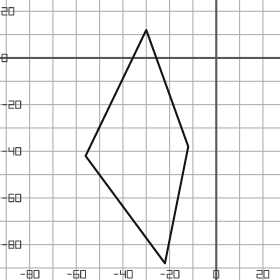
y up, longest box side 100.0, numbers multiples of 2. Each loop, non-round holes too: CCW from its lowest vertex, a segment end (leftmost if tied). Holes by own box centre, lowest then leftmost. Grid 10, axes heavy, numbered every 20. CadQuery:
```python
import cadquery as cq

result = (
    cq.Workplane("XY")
    .moveTo(-22.0, -88.0)
    .lineTo(-12.0, -38.0)
    .lineTo(-30.0, 12.0)
    .lineTo(-56.0, -42.0)
    .close()
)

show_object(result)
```